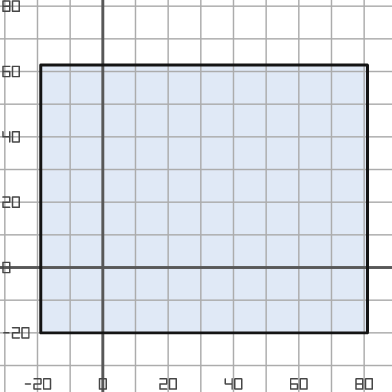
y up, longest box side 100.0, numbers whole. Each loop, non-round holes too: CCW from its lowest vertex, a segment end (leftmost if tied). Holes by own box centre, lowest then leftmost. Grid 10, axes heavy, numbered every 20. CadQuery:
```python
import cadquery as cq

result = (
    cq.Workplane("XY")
    .moveTo(-19.0, -20.0)
    .lineTo(81.0, -20.0)
    .lineTo(81.0, 62.0)
    .lineTo(-19.0, 62.0)
    .close()
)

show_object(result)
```